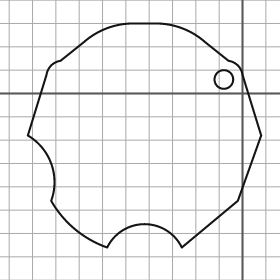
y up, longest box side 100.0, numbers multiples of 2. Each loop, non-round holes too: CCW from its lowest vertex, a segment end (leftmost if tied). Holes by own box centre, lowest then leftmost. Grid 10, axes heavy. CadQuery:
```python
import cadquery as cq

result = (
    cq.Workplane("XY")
    .moveTo(-58.0, -66.0)
    .threePointArc((-42.0, -56.0), (-26.0, -66.0))
    .lineTo(-2.0, -46.0)
    .lineTo(8.0, -18.0)
    .lineTo(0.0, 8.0)
    .threePointArc((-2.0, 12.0), (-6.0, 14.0))
    .lineTo(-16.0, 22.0)
    .threePointArc((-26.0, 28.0), (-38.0, 30.0))
    .lineTo(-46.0, 30.0)
    .threePointArc((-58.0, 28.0), (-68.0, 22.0))
    .lineTo(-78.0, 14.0)
    .threePointArc((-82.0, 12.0), (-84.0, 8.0))
    .lineTo(-92.0, -18.0)
    .threePointArc((-82.0, -30.0), (-82.0, -46.0))
    .threePointArc((-72.0, -58.0), (-58.0, -66.0))
    .close()
    .moveTo(-8.0, 6.0)
    .circle(4.0)
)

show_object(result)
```